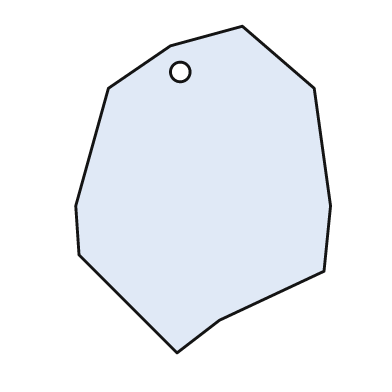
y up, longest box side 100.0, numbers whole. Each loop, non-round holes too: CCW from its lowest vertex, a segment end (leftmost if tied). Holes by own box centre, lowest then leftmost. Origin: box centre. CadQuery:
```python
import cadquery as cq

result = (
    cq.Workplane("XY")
    .moveTo(-8.0, -50.0)
    .lineTo(5.0, -40.0)
    .lineTo(37.0, -25.0)
    .lineTo(39.0, -5.0)
    .lineTo(34.0, 31.0)
    .lineTo(12.0, 50.0)
    .lineTo(-10.0, 44.0)
    .lineTo(-29.0, 31.0)
    .lineTo(-39.0, -5.0)
    .lineTo(-38.0, -20.0)
    .close()
    .moveTo(-7.0, 36.0)
    .circle(3.0)
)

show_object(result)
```